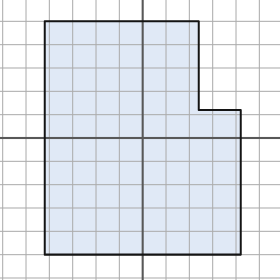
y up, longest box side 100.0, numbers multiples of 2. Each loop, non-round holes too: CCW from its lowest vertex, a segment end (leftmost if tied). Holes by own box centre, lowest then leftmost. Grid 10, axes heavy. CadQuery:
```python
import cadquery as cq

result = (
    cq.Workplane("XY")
    .moveTo(-42.0, -50.0)
    .lineTo(42.0, -50.0)
    .lineTo(42.0, 12.0)
    .lineTo(24.0, 12.0)
    .lineTo(24.0, 50.0)
    .lineTo(-42.0, 50.0)
    .close()
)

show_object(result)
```